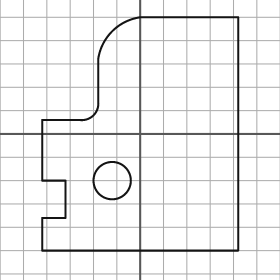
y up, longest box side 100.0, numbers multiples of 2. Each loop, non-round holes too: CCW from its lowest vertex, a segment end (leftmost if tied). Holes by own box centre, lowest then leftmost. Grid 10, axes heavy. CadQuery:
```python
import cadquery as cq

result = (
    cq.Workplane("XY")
    .moveTo(-42.0, -50.0)
    .lineTo(42.0, -50.0)
    .lineTo(42.0, 50.0)
    .lineTo(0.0, 50.0)
    .threePointArc((-12.0, 44.0), (-18.0, 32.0))
    .lineTo(-18.0, 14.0)
    .threePointArc((-20.0, 8.0), (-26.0, 6.0))
    .lineTo(-42.0, 6.0)
    .lineTo(-42.0, -20.0)
    .lineTo(-32.0, -20.0)
    .lineTo(-32.0, -36.0)
    .lineTo(-42.0, -36.0)
    .close()
    .moveTo(-12.0, -20.0)
    .circle(8.0)
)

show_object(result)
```